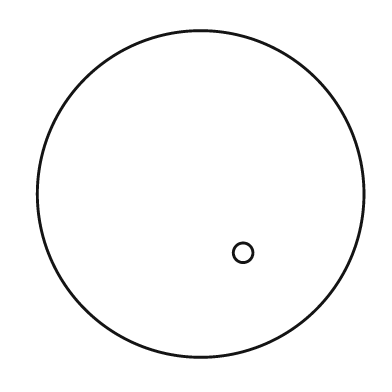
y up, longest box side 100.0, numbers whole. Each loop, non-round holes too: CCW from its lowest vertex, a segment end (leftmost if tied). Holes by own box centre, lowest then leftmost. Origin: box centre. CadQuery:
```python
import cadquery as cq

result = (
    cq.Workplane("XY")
    .moveTo(0.0, 0.0)
    .circle(50.0)
    .moveTo(13.0, -18.0)
    .circle(3.0)
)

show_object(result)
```